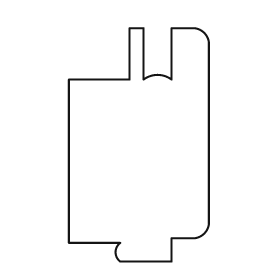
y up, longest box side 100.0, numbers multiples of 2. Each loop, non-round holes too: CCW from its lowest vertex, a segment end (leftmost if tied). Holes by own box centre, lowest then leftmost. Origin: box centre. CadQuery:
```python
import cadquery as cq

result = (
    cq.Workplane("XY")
    .moveTo(-8.0, -50.0)
    .lineTo(14.0, -50.0)
    .lineTo(14.0, -40.0)
    .lineTo(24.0, -40.0)
    .threePointArc((28.0, -38.0), (30.0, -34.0))
    .lineTo(30.0, 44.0)
    .threePointArc((28.0, 48.0), (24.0, 50.0))
    .lineTo(14.0, 50.0)
    .lineTo(14.0, 28.0)
    .threePointArc((8.0, 30.0), (2.0, 28.0))
    .lineTo(2.0, 50.0)
    .lineTo(-4.0, 50.0)
    .lineTo(-4.0, 28.0)
    .lineTo(-30.0, 28.0)
    .lineTo(-30.0, -42.0)
    .lineTo(-8.0, -42.0)
    .threePointArc((-10.0, -46.0), (-8.0, -50.0))
    .close()
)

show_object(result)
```